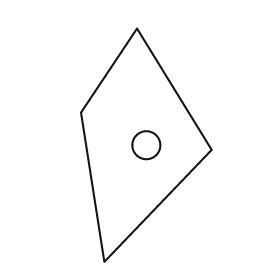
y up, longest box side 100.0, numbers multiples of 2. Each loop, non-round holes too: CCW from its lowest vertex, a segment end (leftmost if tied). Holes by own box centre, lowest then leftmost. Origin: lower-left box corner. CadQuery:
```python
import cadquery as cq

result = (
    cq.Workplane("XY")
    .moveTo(10.0, 0.0)
    .lineTo(56.0, 48.0)
    .lineTo(24.0, 100.0)
    .lineTo(0.0, 64.0)
    .close()
    .moveTo(28.0, 50.0)
    .circle(6.0)
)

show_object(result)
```